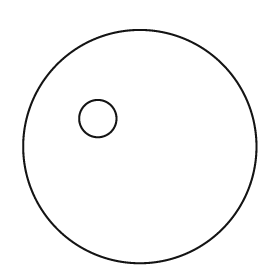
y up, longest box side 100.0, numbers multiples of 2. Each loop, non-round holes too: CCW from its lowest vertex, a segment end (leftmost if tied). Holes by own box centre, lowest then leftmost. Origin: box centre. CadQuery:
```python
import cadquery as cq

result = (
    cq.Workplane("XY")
    .moveTo(0.0, 0.0)
    .circle(50.0)
    .moveTo(-18.0, 12.0)
    .circle(8.0)
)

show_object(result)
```